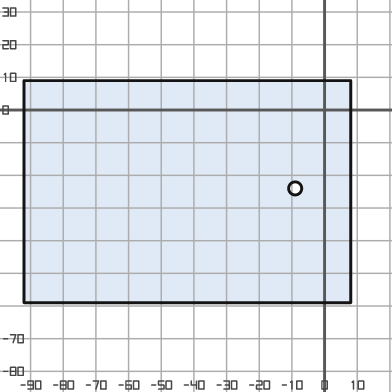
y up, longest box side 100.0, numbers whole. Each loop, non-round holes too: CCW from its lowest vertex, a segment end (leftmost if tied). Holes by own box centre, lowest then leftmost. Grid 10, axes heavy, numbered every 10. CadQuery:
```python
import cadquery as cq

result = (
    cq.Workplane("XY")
    .moveTo(-92.0, -59.0)
    .lineTo(8.0, -59.0)
    .lineTo(8.0, 9.0)
    .lineTo(-92.0, 9.0)
    .close()
    .moveTo(-9.0, -24.0)
    .circle(2.0)
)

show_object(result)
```